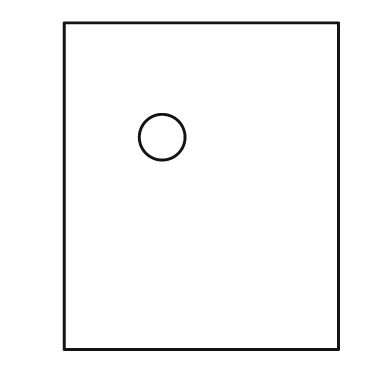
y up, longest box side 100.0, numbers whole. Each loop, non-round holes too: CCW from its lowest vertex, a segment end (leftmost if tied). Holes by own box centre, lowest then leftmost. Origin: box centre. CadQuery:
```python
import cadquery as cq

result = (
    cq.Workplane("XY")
    .moveTo(-42.0, -50.0)
    .lineTo(42.0, -50.0)
    .lineTo(42.0, 50.0)
    .lineTo(-42.0, 50.0)
    .close()
    .moveTo(-12.0, 15.0)
    .circle(7.0)
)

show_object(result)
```